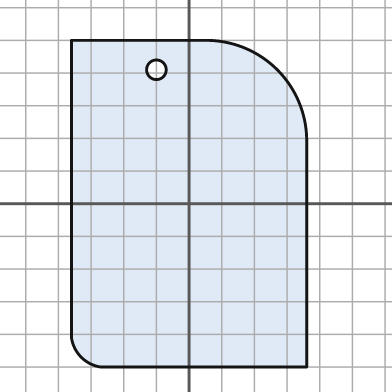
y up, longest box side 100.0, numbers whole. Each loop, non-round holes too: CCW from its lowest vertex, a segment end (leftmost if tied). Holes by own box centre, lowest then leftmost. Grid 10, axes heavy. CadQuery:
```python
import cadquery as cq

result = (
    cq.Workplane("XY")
    .moveTo(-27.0, -50.0)
    .lineTo(36.0, -50.0)
    .lineTo(36.0, 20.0)
    .threePointArc((27.0, 41.0), (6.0, 50.0))
    .lineTo(-36.0, 50.0)
    .lineTo(-36.0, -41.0)
    .threePointArc((-33.0, -47.0), (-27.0, -50.0))
    .close()
    .moveTo(-10.0, 41.0)
    .circle(3.0)
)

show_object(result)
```